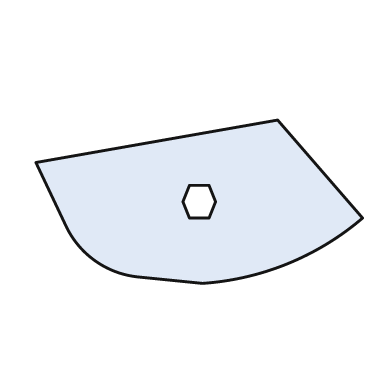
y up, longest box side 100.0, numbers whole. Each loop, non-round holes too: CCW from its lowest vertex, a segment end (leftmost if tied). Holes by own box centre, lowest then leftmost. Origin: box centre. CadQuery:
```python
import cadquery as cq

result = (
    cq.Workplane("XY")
    .moveTo(1.0, -25.0)
    .threePointArc((27.0, -19.0), (50.0, -5.0))
    .lineTo(24.0, 25.0)
    .lineTo(-50.0, 12.0)
    .lineTo(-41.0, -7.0)
    .threePointArc((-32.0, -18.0), (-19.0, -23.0))
    .close()
    .moveTo(-3.0, -5.0)
    .lineTo(3.0, -5.0)
    .lineTo(5.0, 0.0)
    .lineTo(3.0, 5.0)
    .lineTo(-3.0, 5.0)
    .lineTo(-5.0, 0.0)
    .close()
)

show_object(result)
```